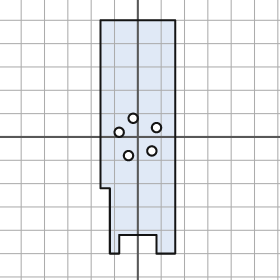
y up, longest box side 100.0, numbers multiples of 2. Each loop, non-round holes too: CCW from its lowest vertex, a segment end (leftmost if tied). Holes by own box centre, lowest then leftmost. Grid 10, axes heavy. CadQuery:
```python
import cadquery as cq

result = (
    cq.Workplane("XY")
    .moveTo(-12.0, -50.0)
    .lineTo(-8.0, -50.0)
    .lineTo(-8.0, -42.0)
    .lineTo(8.0, -42.0)
    .lineTo(8.0, -50.0)
    .lineTo(16.0, -50.0)
    .lineTo(16.0, 50.0)
    .lineTo(-16.0, 50.0)
    .lineTo(-16.0, -22.0)
    .lineTo(-12.0, -22.0)
    .close()
    .moveTo(-4.0, -8.0)
    .circle(2.0)
    .moveTo(6.0, -6.0)
    .circle(2.0)
    .moveTo(-8.0, 2.0)
    .circle(2.0)
    .moveTo(8.0, 4.0)
    .circle(2.0)
    .moveTo(-2.0, 8.0)
    .circle(2.0)
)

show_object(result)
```